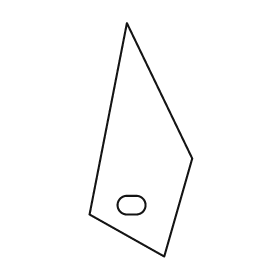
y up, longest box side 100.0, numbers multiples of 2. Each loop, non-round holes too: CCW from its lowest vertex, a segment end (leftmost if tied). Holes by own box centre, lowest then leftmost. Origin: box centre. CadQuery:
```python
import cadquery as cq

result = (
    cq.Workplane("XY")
    .moveTo(10.0, -50.0)
    .lineTo(22.0, -8.0)
    .lineTo(-6.0, 50.0)
    .lineTo(-22.0, -32.0)
    .close()
    .moveTo(-6.0, -32.0)
    .lineTo(-2.0, -32.0)
    .threePointArc((2.0, -28.0), (-2.0, -24.0))
    .lineTo(-6.0, -24.0)
    .threePointArc((-10.0, -28.0), (-6.0, -32.0))
    .close()
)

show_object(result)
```